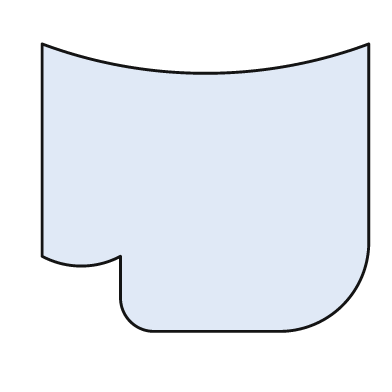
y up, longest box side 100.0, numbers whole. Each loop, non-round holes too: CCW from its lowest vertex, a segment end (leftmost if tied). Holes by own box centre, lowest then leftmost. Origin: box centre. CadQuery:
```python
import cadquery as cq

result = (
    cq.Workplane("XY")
    .moveTo(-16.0, -44.0)
    .lineTo(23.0, -44.0)
    .threePointArc((42.0, -36.0), (50.0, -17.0))
    .lineTo(50.0, 44.0)
    .threePointArc((0.0, 35.0), (-50.0, 44.0))
    .lineTo(-50.0, -21.0)
    .threePointArc((-38.0, -24.0), (-26.0, -21.0))
    .lineTo(-26.0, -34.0)
    .threePointArc((-23.0, -41.0), (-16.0, -44.0))
    .close()
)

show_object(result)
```